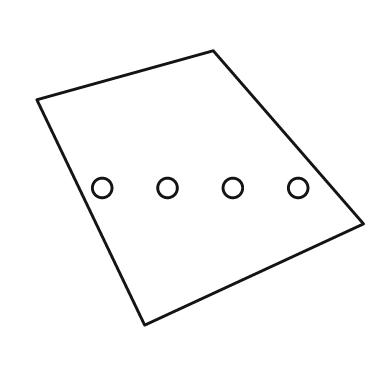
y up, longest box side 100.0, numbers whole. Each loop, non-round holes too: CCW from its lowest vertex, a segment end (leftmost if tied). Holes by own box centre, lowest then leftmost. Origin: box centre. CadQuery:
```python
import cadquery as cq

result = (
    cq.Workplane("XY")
    .moveTo(-17.0, -42.0)
    .lineTo(50.0, -11.0)
    .lineTo(4.0, 42.0)
    .lineTo(-50.0, 27.0)
    .close()
    .moveTo(-30.0, 0.0)
    .circle(3.0)
    .moveTo(-10.0, 0.0)
    .circle(3.0)
    .moveTo(10.0, 0.0)
    .circle(3.0)
    .moveTo(30.0, 0.0)
    .circle(3.0)
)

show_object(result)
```